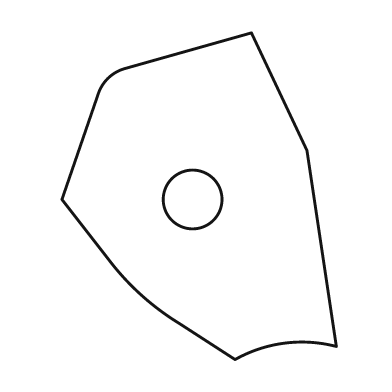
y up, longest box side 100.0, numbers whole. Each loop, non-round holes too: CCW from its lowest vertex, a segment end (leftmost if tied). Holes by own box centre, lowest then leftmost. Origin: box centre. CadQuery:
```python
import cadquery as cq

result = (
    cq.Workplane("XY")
    .moveTo(11.0, -50.0)
    .threePointArc((26.0, -45.0), (42.0, -46.0))
    .lineTo(33.0, 14.0)
    .lineTo(16.0, 50.0)
    .lineTo(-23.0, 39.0)
    .threePointArc((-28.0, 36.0), (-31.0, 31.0))
    .lineTo(-42.0, -1.0)
    .lineTo(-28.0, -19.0)
    .threePointArc((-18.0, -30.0), (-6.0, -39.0))
    .close()
    .moveTo(-2.0, -1.0)
    .circle(9.0)
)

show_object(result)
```